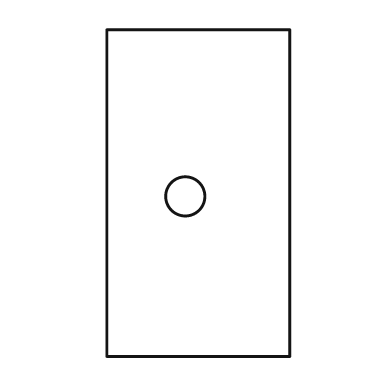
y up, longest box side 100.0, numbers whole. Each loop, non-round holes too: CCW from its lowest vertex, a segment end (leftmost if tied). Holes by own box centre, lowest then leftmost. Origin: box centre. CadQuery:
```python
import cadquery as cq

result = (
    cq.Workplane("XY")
    .moveTo(-28.0, -50.0)
    .lineTo(28.0, -50.0)
    .lineTo(28.0, 50.0)
    .lineTo(-28.0, 50.0)
    .close()
    .moveTo(-4.0, -1.0)
    .circle(6.0)
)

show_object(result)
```